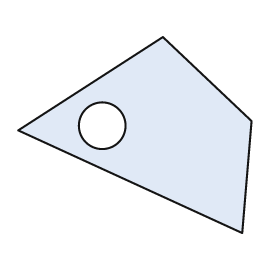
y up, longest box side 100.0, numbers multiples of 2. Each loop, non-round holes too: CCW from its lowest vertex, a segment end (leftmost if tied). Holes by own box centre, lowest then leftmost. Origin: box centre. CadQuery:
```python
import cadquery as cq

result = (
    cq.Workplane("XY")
    .moveTo(46.0, -42.0)
    .lineTo(50.0, 6.0)
    .lineTo(12.0, 42.0)
    .lineTo(-50.0, 2.0)
    .close()
    .moveTo(-14.0, 4.0)
    .circle(10.0)
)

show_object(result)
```